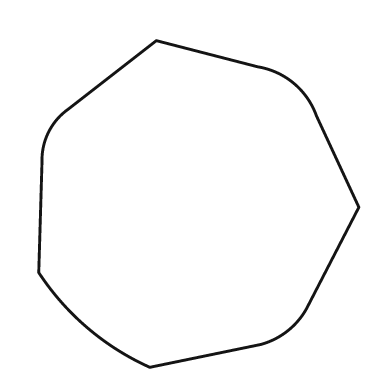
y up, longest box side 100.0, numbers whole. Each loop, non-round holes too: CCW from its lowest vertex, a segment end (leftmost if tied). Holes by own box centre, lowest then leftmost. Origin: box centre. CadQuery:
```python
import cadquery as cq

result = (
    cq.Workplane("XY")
    .moveTo(-15.0, -50.0)
    .lineTo(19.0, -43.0)
    .threePointArc((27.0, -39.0), (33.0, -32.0))
    .lineTo(49.0, -1.0)
    .lineTo(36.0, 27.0)
    .threePointArc((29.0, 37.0), (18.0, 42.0))
    .lineTo(-13.0, 50.0)
    .lineTo(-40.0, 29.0)
    .threePointArc((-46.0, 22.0), (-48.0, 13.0))
    .lineTo(-49.0, -21.0)
    .threePointArc((-34.0, -38.0), (-15.0, -50.0))
    .close()
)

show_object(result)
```